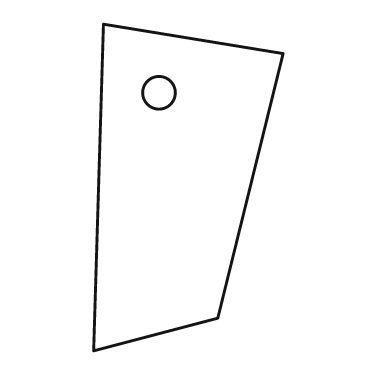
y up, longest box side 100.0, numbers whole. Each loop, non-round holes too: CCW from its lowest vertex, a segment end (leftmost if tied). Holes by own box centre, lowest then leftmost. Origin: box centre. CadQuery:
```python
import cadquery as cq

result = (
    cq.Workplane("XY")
    .moveTo(-29.0, -50.0)
    .lineTo(9.0, -40.0)
    .lineTo(29.0, 41.0)
    .lineTo(-26.0, 50.0)
    .close()
    .moveTo(-9.0, 29.0)
    .circle(5.0)
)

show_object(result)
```